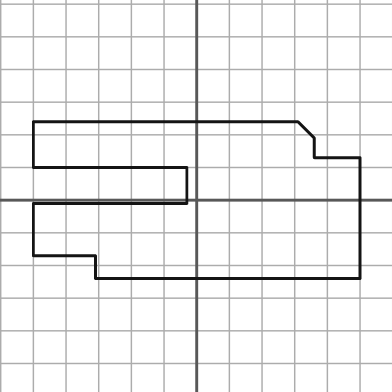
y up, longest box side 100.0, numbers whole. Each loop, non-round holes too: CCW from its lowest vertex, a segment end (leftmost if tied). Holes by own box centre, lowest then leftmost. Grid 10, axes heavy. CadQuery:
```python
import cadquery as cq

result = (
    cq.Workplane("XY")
    .moveTo(-31.0, -24.0)
    .lineTo(50.0, -24.0)
    .lineTo(50.0, 13.0)
    .lineTo(36.0, 13.0)
    .lineTo(36.0, 19.0)
    .lineTo(31.0, 24.0)
    .lineTo(-50.0, 24.0)
    .lineTo(-50.0, 10.0)
    .lineTo(-3.0, 10.0)
    .lineTo(-3.0, -1.0)
    .lineTo(-50.0, -1.0)
    .lineTo(-50.0, -17.0)
    .lineTo(-31.0, -17.0)
    .close()
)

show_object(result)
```